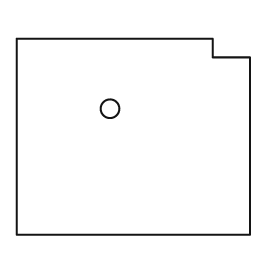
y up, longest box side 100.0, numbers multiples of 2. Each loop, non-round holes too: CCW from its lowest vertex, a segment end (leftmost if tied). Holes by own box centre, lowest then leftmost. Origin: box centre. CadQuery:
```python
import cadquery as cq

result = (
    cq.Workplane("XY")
    .moveTo(-50.0, -42.0)
    .lineTo(50.0, -42.0)
    .lineTo(50.0, 34.0)
    .lineTo(34.0, 34.0)
    .lineTo(34.0, 42.0)
    .lineTo(-50.0, 42.0)
    .close()
    .moveTo(-10.0, 12.0)
    .circle(4.0)
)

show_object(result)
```